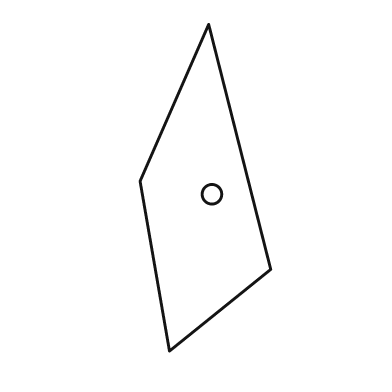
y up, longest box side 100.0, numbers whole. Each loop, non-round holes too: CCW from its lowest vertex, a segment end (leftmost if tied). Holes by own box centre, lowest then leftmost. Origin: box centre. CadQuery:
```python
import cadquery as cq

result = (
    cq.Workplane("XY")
    .moveTo(-11.0, -50.0)
    .lineTo(20.0, -25.0)
    .lineTo(1.0, 50.0)
    .lineTo(-20.0, 2.0)
    .close()
    .moveTo(2.0, -2.0)
    .circle(3.0)
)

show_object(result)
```